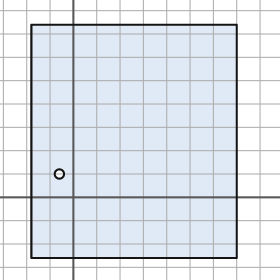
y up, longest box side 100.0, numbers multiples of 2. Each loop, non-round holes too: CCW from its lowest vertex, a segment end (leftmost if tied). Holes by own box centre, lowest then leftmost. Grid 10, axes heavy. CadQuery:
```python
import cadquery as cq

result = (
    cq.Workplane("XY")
    .moveTo(-18.0, -26.0)
    .lineTo(70.0, -26.0)
    .lineTo(70.0, 74.0)
    .lineTo(-18.0, 74.0)
    .close()
    .moveTo(-6.0, 10.0)
    .circle(2.0)
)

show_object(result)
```